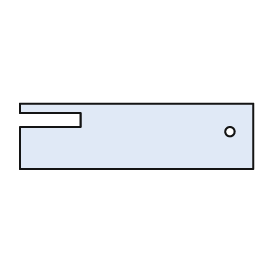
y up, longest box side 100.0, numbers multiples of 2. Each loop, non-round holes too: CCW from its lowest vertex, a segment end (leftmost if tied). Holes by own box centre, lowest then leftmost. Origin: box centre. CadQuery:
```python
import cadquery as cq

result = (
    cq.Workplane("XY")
    .moveTo(-50.0, -14.0)
    .lineTo(50.0, -14.0)
    .lineTo(50.0, 14.0)
    .lineTo(-50.0, 14.0)
    .lineTo(-50.0, 10.0)
    .lineTo(-24.0, 10.0)
    .lineTo(-24.0, 4.0)
    .lineTo(-50.0, 4.0)
    .close()
    .moveTo(40.0, 2.0)
    .circle(2.0)
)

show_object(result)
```